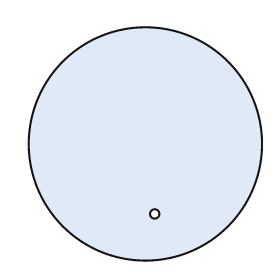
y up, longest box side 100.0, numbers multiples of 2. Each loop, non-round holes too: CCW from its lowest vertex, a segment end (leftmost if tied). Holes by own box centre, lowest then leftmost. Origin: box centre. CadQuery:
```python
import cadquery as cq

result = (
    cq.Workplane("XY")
    .moveTo(0.0, 0.0)
    .circle(50.0)
    .moveTo(4.0, -30.0)
    .circle(2.0)
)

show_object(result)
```